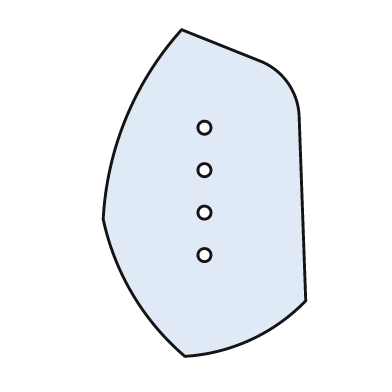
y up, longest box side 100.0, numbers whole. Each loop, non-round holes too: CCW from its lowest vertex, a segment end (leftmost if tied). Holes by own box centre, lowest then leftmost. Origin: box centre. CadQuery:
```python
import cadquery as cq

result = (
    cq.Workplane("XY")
    .moveTo(-6.0, -50.0)
    .threePointArc((14.0, -45.0), (31.0, -33.0))
    .lineTo(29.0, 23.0)
    .threePointArc((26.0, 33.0), (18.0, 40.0))
    .lineTo(-7.0, 50.0)
    .threePointArc((-24.0, 23.0), (-31.0, -8.0))
    .threePointArc((-22.0, -31.0), (-6.0, -50.0))
    .close()
    .moveTo(0.0, -19.0)
    .circle(2.0)
    .moveTo(0.0, -6.0)
    .circle(2.0)
    .moveTo(0.0, 7.0)
    .circle(2.0)
    .moveTo(0.0, 20.0)
    .circle(2.0)
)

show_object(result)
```